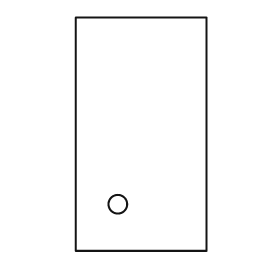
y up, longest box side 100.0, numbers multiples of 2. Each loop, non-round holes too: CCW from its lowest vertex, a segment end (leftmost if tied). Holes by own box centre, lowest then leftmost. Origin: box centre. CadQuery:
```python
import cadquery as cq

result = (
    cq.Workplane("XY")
    .moveTo(-28.0, -50.0)
    .lineTo(28.0, -50.0)
    .lineTo(28.0, 50.0)
    .lineTo(-28.0, 50.0)
    .close()
    .moveTo(-10.0, -30.0)
    .circle(4.0)
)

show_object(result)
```